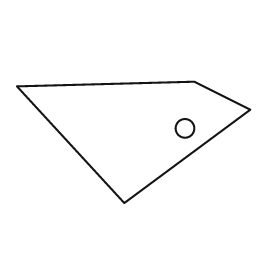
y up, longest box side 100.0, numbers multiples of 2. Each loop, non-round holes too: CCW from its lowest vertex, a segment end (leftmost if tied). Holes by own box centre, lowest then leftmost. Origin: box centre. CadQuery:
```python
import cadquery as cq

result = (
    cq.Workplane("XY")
    .moveTo(-4.0, -26.0)
    .lineTo(50.0, 14.0)
    .lineTo(26.0, 26.0)
    .lineTo(-50.0, 24.0)
    .close()
    .moveTo(22.0, 6.0)
    .circle(4.0)
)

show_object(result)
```